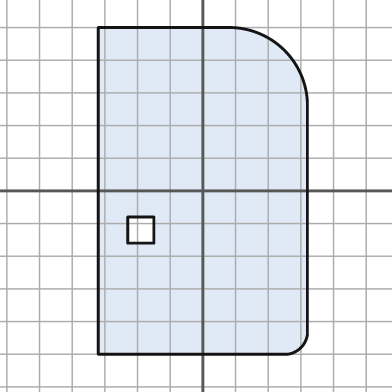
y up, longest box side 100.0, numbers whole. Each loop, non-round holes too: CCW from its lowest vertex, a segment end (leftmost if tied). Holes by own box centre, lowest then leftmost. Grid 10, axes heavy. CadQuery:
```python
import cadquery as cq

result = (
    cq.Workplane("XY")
    .moveTo(-32.0, -50.0)
    .lineTo(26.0, -50.0)
    .threePointArc((30.0, -48.0), (32.0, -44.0))
    .lineTo(32.0, 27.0)
    .threePointArc((25.0, 43.0), (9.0, 50.0))
    .lineTo(-32.0, 50.0)
    .close()
    .moveTo(-23.0, -16.0)
    .lineTo(-15.0, -16.0)
    .lineTo(-15.0, -8.0)
    .lineTo(-23.0, -8.0)
    .close()
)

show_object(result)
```